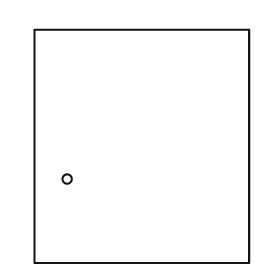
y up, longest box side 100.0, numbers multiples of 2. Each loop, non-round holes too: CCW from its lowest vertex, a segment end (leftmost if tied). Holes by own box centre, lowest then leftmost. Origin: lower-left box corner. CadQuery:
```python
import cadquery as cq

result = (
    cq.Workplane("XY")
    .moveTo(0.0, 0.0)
    .lineTo(92.0, 0.0)
    .lineTo(92.0, 100.0)
    .lineTo(0.0, 100.0)
    .close()
    .moveTo(14.0, 36.0)
    .circle(2.0)
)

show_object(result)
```